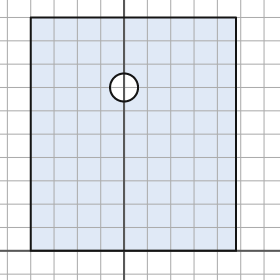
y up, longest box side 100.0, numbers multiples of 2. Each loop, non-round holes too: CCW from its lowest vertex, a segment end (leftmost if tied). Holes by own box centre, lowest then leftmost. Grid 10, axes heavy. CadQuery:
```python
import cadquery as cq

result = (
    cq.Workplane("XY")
    .moveTo(-40.0, 0.0)
    .lineTo(48.0, 0.0)
    .lineTo(48.0, 100.0)
    .lineTo(-40.0, 100.0)
    .close()
    .moveTo(0.0, 70.0)
    .circle(6.0)
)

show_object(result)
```